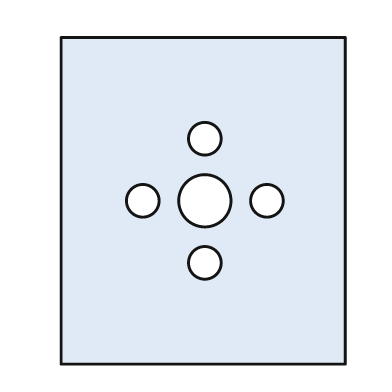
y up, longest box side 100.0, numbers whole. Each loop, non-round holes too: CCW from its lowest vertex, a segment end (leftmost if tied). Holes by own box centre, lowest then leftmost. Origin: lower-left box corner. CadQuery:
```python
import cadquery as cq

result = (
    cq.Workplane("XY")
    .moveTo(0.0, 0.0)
    .lineTo(87.0, 0.0)
    .lineTo(87.0, 100.0)
    .lineTo(0.0, 100.0)
    .close()
    .moveTo(44.0, 31.0)
    .circle(5.0)
    .moveTo(25.0, 50.0)
    .circle(5.0)
    .moveTo(44.0, 50.0)
    .circle(8.0)
    .moveTo(63.0, 50.0)
    .circle(5.0)
    .moveTo(44.0, 69.0)
    .circle(5.0)
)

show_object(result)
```